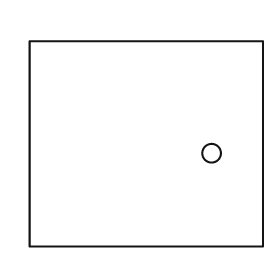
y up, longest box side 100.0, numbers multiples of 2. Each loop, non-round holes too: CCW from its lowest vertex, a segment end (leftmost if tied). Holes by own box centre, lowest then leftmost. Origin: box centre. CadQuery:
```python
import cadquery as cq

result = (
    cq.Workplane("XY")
    .moveTo(-50.0, -44.0)
    .lineTo(50.0, -44.0)
    .lineTo(50.0, 44.0)
    .lineTo(-50.0, 44.0)
    .close()
    .moveTo(28.0, -4.0)
    .circle(4.0)
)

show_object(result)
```